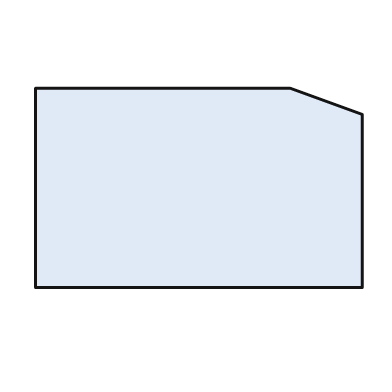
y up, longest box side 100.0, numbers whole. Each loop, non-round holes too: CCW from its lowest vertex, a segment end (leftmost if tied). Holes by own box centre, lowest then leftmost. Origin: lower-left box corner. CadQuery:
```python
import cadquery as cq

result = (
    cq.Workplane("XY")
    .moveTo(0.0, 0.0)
    .lineTo(100.0, 0.0)
    .lineTo(100.0, 53.0)
    .lineTo(78.0, 61.0)
    .lineTo(0.0, 61.0)
    .close()
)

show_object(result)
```